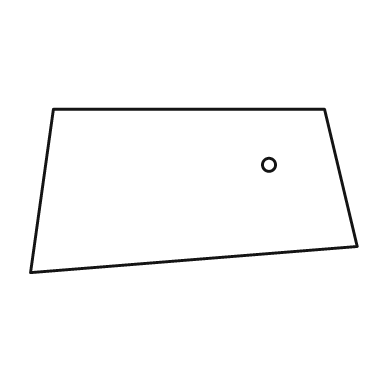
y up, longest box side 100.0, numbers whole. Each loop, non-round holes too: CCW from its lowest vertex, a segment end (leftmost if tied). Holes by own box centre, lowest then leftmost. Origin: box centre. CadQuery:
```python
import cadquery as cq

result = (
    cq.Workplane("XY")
    .moveTo(-50.0, -25.0)
    .lineTo(50.0, -17.0)
    .lineTo(40.0, 25.0)
    .lineTo(-43.0, 25.0)
    .close()
    .moveTo(23.0, 8.0)
    .circle(2.0)
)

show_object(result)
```